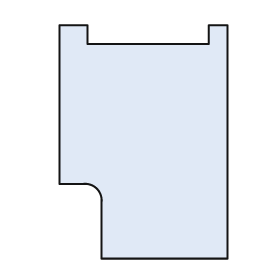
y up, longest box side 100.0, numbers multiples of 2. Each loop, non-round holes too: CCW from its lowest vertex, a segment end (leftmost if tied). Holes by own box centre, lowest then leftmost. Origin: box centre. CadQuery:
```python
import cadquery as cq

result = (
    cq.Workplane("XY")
    .moveTo(-18.0, -50.0)
    .lineTo(36.0, -50.0)
    .lineTo(36.0, 50.0)
    .lineTo(28.0, 50.0)
    .lineTo(28.0, 42.0)
    .lineTo(-24.0, 42.0)
    .lineTo(-24.0, 50.0)
    .lineTo(-36.0, 50.0)
    .lineTo(-36.0, -18.0)
    .lineTo(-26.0, -18.0)
    .threePointArc((-20.0, -20.0), (-18.0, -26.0))
    .close()
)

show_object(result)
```